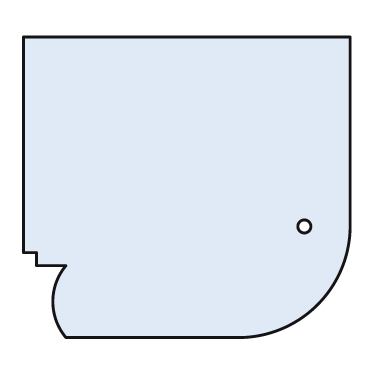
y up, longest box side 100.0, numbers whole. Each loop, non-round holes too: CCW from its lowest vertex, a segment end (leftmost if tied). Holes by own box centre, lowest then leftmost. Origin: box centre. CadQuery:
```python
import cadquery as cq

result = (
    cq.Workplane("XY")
    .moveTo(-37.0, -46.0)
    .lineTo(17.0, -46.0)
    .threePointArc((40.0, -36.0), (50.0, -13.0))
    .lineTo(50.0, 46.0)
    .lineTo(-50.0, 46.0)
    .lineTo(-50.0, -20.0)
    .lineTo(-46.0, -20.0)
    .lineTo(-46.0, -24.0)
    .lineTo(-37.0, -24.0)
    .threePointArc((-41.0, -35.0), (-37.0, -46.0))
    .close()
    .moveTo(36.0, -12.0)
    .circle(2.0)
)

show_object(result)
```